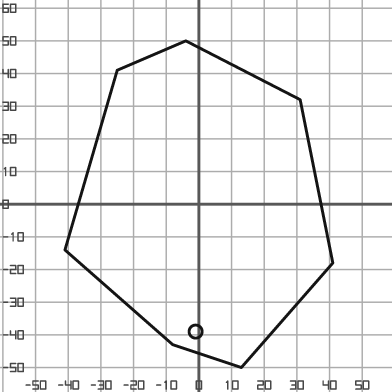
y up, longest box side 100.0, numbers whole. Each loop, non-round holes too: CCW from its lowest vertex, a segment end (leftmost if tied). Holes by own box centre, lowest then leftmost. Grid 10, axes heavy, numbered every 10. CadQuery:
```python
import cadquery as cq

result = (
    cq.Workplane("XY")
    .moveTo(13.0, -50.0)
    .lineTo(41.0, -18.0)
    .lineTo(31.0, 32.0)
    .lineTo(-4.0, 50.0)
    .lineTo(-25.0, 41.0)
    .lineTo(-41.0, -14.0)
    .lineTo(-8.0, -43.0)
    .close()
    .moveTo(-1.0, -39.0)
    .circle(2.0)
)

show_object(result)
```